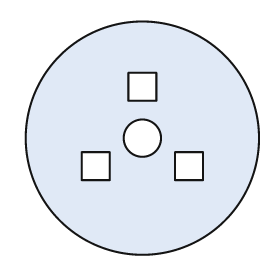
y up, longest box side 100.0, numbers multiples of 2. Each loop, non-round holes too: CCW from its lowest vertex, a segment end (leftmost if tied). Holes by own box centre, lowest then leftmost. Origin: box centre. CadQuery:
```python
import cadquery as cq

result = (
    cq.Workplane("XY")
    .moveTo(0.0, 0.0)
    .circle(50.0)
    .moveTo(-26.0, -18.0)
    .lineTo(-14.0, -18.0)
    .lineTo(-14.0, -6.0)
    .lineTo(-26.0, -6.0)
    .close()
    .moveTo(14.0, -18.0)
    .lineTo(26.0, -18.0)
    .lineTo(26.0, -6.0)
    .lineTo(14.0, -6.0)
    .close()
    .moveTo(0.0, 0.0)
    .circle(8.0)
    .moveTo(-6.0, 16.0)
    .lineTo(6.0, 16.0)
    .lineTo(6.0, 28.0)
    .lineTo(-6.0, 28.0)
    .close()
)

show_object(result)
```